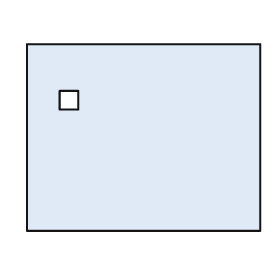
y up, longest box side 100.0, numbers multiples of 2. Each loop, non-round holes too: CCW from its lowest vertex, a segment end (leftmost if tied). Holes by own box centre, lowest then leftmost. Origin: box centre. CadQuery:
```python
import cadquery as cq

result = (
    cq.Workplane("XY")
    .moveTo(-50.0, -40.0)
    .lineTo(50.0, -40.0)
    .lineTo(50.0, 40.0)
    .lineTo(-50.0, 40.0)
    .close()
    .moveTo(-36.0, 12.0)
    .lineTo(-28.0, 12.0)
    .lineTo(-28.0, 20.0)
    .lineTo(-36.0, 20.0)
    .close()
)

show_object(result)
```